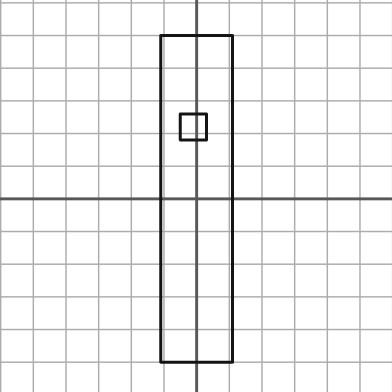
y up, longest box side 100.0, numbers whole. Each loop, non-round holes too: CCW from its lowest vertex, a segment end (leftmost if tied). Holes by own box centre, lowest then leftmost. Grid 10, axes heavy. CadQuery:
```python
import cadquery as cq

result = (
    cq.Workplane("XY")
    .moveTo(-11.0, -50.0)
    .lineTo(11.0, -50.0)
    .lineTo(11.0, 50.0)
    .lineTo(-11.0, 50.0)
    .close()
    .moveTo(-5.0, 18.0)
    .lineTo(3.0, 18.0)
    .lineTo(3.0, 26.0)
    .lineTo(-5.0, 26.0)
    .close()
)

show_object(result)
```